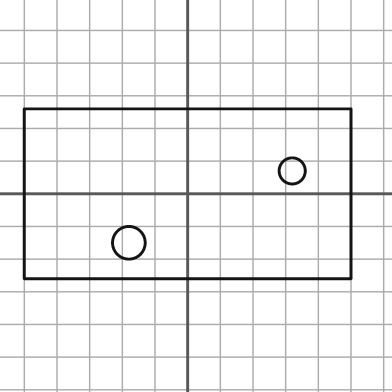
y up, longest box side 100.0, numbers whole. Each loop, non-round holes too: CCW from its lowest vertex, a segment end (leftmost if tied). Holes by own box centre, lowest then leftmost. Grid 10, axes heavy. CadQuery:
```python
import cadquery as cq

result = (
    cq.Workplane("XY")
    .moveTo(-50.0, -26.0)
    .lineTo(50.0, -26.0)
    .lineTo(50.0, 26.0)
    .lineTo(-50.0, 26.0)
    .close()
    .moveTo(-18.0, -15.0)
    .circle(5.0)
    .moveTo(32.0, 7.0)
    .circle(4.0)
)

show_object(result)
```